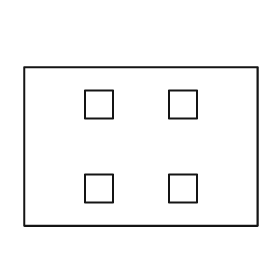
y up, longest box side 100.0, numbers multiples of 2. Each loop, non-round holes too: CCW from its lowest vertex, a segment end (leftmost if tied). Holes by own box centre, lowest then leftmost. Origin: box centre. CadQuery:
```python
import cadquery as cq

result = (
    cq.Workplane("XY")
    .moveTo(-50.0, -34.0)
    .lineTo(50.0, -34.0)
    .lineTo(50.0, 34.0)
    .lineTo(-50.0, 34.0)
    .close()
    .moveTo(-24.0, -24.0)
    .lineTo(-12.0, -24.0)
    .lineTo(-12.0, -12.0)
    .lineTo(-24.0, -12.0)
    .close()
    .moveTo(12.0, -24.0)
    .lineTo(24.0, -24.0)
    .lineTo(24.0, -12.0)
    .lineTo(12.0, -12.0)
    .close()
    .moveTo(-24.0, 12.0)
    .lineTo(-12.0, 12.0)
    .lineTo(-12.0, 24.0)
    .lineTo(-24.0, 24.0)
    .close()
    .moveTo(12.0, 12.0)
    .lineTo(24.0, 12.0)
    .lineTo(24.0, 24.0)
    .lineTo(12.0, 24.0)
    .close()
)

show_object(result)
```